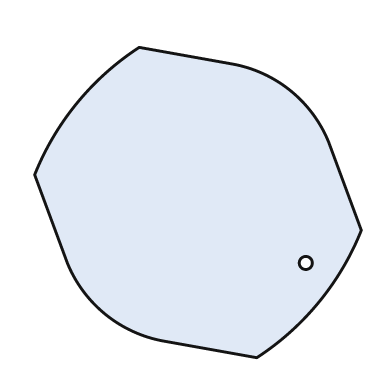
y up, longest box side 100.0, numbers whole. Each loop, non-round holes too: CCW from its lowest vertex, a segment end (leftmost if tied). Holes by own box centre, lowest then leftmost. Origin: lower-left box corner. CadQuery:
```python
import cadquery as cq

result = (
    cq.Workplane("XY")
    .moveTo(68.0, 0.0)
    .threePointArc((87.0, 17.0), (100.0, 39.0))
    .lineTo(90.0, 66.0)
    .threePointArc((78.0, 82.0), (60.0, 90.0))
    .lineTo(32.0, 95.0)
    .threePointArc((13.0, 78.0), (0.0, 56.0))
    .lineTo(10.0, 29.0)
    .threePointArc((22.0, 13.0), (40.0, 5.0))
    .close()
    .moveTo(83.0, 29.0)
    .circle(2.0)
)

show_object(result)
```